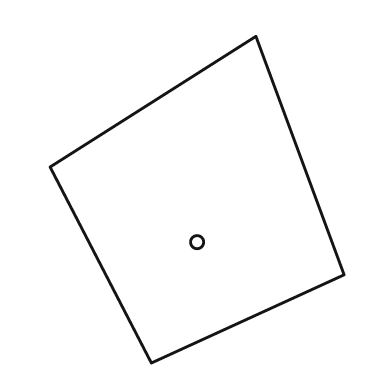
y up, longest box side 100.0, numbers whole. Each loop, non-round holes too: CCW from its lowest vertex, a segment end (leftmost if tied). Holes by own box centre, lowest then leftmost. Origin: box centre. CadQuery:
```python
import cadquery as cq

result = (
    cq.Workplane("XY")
    .moveTo(-14.0, -50.0)
    .lineTo(45.0, -23.0)
    .lineTo(18.0, 50.0)
    .lineTo(-45.0, 10.0)
    .close()
    .moveTo(0.0, -13.0)
    .circle(2.0)
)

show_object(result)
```